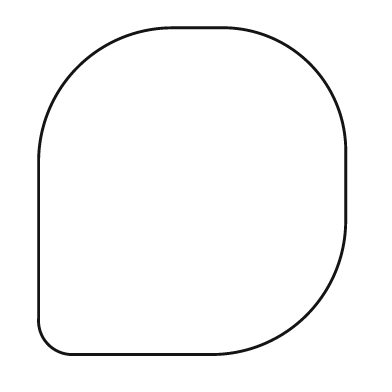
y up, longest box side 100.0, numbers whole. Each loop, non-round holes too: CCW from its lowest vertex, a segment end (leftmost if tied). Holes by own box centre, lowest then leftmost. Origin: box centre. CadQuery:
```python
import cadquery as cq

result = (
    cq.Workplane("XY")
    .moveTo(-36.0, -50.0)
    .lineTo(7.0, -50.0)
    .threePointArc((35.0, -38.0), (47.0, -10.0))
    .lineTo(47.0, 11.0)
    .threePointArc((36.0, 39.0), (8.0, 50.0))
    .lineTo(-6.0, 50.0)
    .threePointArc((-35.0, 38.0), (-47.0, 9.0))
    .lineTo(-47.0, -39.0)
    .threePointArc((-44.0, -47.0), (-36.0, -50.0))
    .close()
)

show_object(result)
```